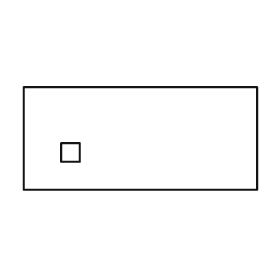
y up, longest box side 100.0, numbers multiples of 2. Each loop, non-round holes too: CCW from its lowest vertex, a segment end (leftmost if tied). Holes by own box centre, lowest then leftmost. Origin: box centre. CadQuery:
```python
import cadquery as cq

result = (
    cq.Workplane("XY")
    .moveTo(-50.0, -22.0)
    .lineTo(50.0, -22.0)
    .lineTo(50.0, 22.0)
    .lineTo(-50.0, 22.0)
    .close()
    .moveTo(-34.0, -10.0)
    .lineTo(-26.0, -10.0)
    .lineTo(-26.0, -2.0)
    .lineTo(-34.0, -2.0)
    .close()
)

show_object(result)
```